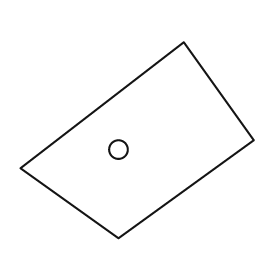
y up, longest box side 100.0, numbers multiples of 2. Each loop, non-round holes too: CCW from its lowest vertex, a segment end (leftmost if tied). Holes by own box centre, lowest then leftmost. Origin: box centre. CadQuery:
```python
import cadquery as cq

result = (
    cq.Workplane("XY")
    .moveTo(-8.0, -42.0)
    .lineTo(50.0, 0.0)
    .lineTo(20.0, 42.0)
    .lineTo(-50.0, -12.0)
    .close()
    .moveTo(-8.0, -4.0)
    .circle(4.0)
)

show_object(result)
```